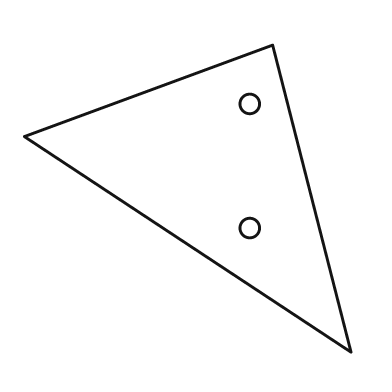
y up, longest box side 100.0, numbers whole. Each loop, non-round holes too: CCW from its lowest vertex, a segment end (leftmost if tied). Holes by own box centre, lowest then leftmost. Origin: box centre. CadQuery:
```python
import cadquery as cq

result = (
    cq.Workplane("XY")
    .moveTo(50.0, -47.0)
    .lineTo(26.0, 47.0)
    .lineTo(-50.0, 19.0)
    .close()
    .moveTo(19.0, -9.0)
    .circle(3.0)
    .moveTo(19.0, 29.0)
    .circle(3.0)
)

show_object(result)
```